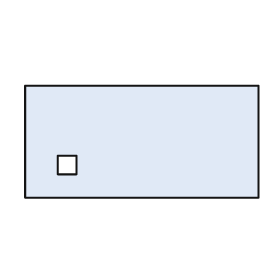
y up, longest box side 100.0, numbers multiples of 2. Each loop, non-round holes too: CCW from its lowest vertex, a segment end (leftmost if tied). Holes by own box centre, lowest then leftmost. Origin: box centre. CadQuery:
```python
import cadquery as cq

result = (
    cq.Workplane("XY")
    .moveTo(-50.0, -24.0)
    .lineTo(50.0, -24.0)
    .lineTo(50.0, 24.0)
    .lineTo(-50.0, 24.0)
    .close()
    .moveTo(-36.0, -14.0)
    .lineTo(-28.0, -14.0)
    .lineTo(-28.0, -6.0)
    .lineTo(-36.0, -6.0)
    .close()
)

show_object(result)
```